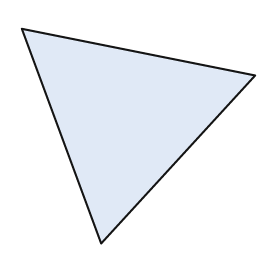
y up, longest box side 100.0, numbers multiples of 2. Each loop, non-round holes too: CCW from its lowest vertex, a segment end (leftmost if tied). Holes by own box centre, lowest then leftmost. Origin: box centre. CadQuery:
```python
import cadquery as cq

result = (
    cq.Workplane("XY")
    .moveTo(-16.0, -46.0)
    .lineTo(50.0, 26.0)
    .lineTo(-50.0, 46.0)
    .close()
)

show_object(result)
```